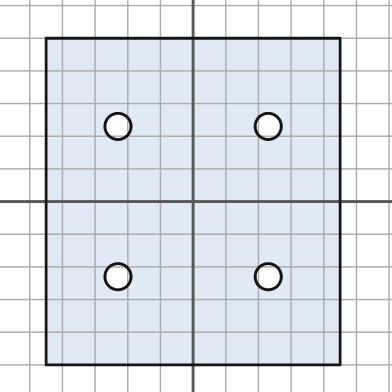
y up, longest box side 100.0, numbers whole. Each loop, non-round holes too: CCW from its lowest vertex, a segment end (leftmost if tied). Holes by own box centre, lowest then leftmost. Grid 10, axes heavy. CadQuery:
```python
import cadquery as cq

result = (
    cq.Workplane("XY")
    .moveTo(-45.0, -50.0)
    .lineTo(45.0, -50.0)
    .lineTo(45.0, 50.0)
    .lineTo(-45.0, 50.0)
    .close()
    .moveTo(-23.0, -23.0)
    .circle(4.0)
    .moveTo(23.0, -23.0)
    .circle(4.0)
    .moveTo(-23.0, 23.0)
    .circle(4.0)
    .moveTo(23.0, 23.0)
    .circle(4.0)
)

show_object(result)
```